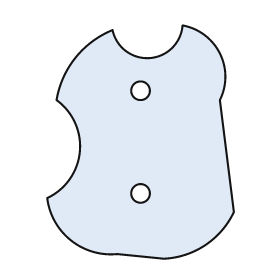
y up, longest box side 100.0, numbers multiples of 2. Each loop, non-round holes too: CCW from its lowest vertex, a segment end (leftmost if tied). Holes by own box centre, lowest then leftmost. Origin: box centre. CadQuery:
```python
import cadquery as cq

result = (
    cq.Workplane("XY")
    .moveTo(10.0, -50.0)
    .threePointArc((28.0, -44.0), (40.0, -30.0))
    .lineTo(34.0, 18.0)
    .threePointArc((34.0, 38.0), (18.0, 50.0))
    .threePointArc((4.0, 36.0), (-12.0, 48.0))
    .threePointArc((-28.0, 36.0), (-36.0, 18.0))
    .threePointArc((-26.0, -4.0), (-40.0, -24.0))
    .threePointArc((-30.0, -42.0), (-10.0, -48.0))
    .close()
    .moveTo(0.0, -22.0)
    .circle(4.0)
    .moveTo(0.0, 22.0)
    .circle(4.0)
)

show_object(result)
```